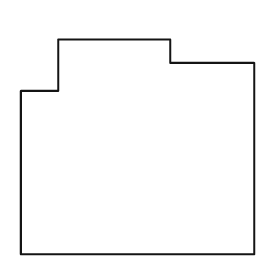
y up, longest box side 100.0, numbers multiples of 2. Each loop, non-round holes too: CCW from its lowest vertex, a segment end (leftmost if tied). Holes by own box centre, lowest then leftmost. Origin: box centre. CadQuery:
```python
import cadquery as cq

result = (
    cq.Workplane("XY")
    .moveTo(-50.0, -46.0)
    .lineTo(50.0, -46.0)
    .lineTo(50.0, 36.0)
    .lineTo(14.0, 36.0)
    .lineTo(14.0, 46.0)
    .lineTo(-34.0, 46.0)
    .lineTo(-34.0, 24.0)
    .lineTo(-50.0, 24.0)
    .close()
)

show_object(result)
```